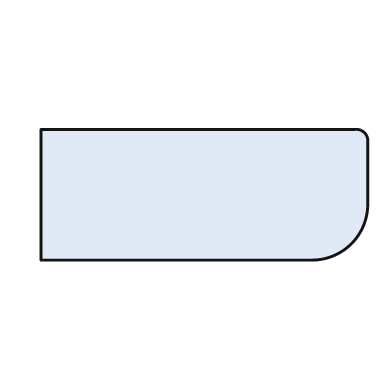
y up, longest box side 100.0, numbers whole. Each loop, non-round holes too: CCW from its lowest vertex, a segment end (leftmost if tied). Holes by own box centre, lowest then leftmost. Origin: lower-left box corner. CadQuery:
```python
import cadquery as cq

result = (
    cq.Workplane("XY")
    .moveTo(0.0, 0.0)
    .lineTo(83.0, 0.0)
    .threePointArc((95.0, 5.0), (100.0, 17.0))
    .lineTo(100.0, 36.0)
    .threePointArc((99.0, 39.0), (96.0, 40.0))
    .lineTo(0.0, 40.0)
    .close()
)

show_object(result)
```